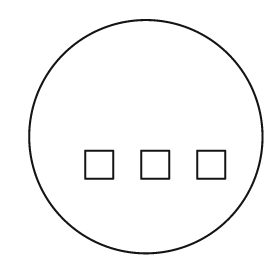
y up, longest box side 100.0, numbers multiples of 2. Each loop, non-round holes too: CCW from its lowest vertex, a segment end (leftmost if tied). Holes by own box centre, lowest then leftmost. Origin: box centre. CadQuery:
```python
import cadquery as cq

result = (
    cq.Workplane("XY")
    .moveTo(0.0, 0.0)
    .circle(50.0)
    .moveTo(-26.0, -18.0)
    .lineTo(-14.0, -18.0)
    .lineTo(-14.0, -6.0)
    .lineTo(-26.0, -6.0)
    .close()
    .moveTo(-2.0, -18.0)
    .lineTo(10.0, -18.0)
    .lineTo(10.0, -6.0)
    .lineTo(-2.0, -6.0)
    .close()
    .moveTo(22.0, -18.0)
    .lineTo(34.0, -18.0)
    .lineTo(34.0, -6.0)
    .lineTo(22.0, -6.0)
    .close()
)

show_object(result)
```